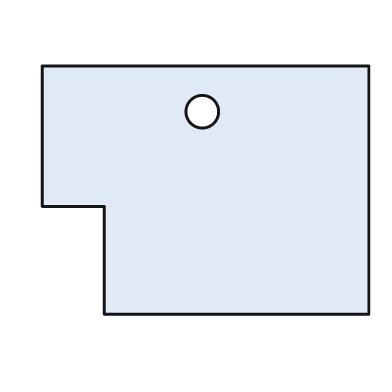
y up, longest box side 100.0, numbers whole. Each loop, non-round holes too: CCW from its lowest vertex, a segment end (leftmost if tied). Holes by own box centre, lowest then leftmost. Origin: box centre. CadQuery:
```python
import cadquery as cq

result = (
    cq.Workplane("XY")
    .moveTo(-31.0, -38.0)
    .lineTo(50.0, -38.0)
    .lineTo(50.0, 38.0)
    .lineTo(-50.0, 38.0)
    .lineTo(-50.0, -5.0)
    .lineTo(-31.0, -5.0)
    .close()
    .moveTo(-1.0, 24.0)
    .circle(5.0)
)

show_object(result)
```